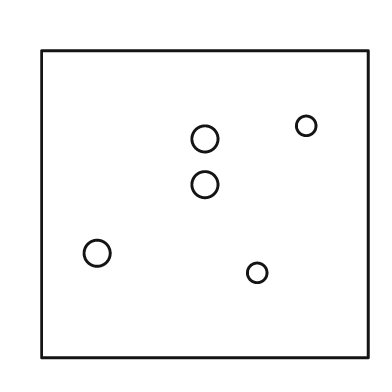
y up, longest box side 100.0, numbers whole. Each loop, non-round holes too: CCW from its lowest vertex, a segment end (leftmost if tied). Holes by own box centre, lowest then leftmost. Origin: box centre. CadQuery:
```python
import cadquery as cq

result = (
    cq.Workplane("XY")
    .moveTo(-50.0, -47.0)
    .lineTo(50.0, -47.0)
    .lineTo(50.0, 47.0)
    .lineTo(-50.0, 47.0)
    .close()
    .moveTo(16.0, -21.0)
    .circle(3.0)
    .moveTo(-33.0, -15.0)
    .circle(4.0)
    .moveTo(0.0, 6.0)
    .circle(4.0)
    .moveTo(0.0, 20.0)
    .circle(4.0)
    .moveTo(31.0, 24.0)
    .circle(3.0)
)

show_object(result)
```